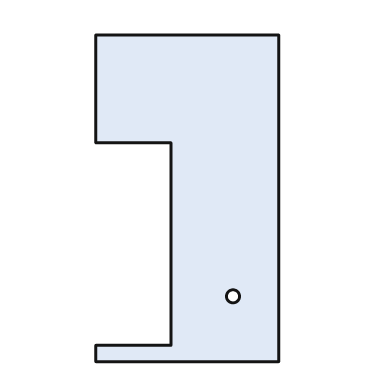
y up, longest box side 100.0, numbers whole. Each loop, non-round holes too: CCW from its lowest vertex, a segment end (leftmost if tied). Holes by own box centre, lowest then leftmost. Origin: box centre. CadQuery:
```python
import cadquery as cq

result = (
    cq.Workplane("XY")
    .moveTo(-28.0, -50.0)
    .lineTo(28.0, -50.0)
    .lineTo(28.0, 50.0)
    .lineTo(-28.0, 50.0)
    .lineTo(-28.0, 17.0)
    .lineTo(-5.0, 17.0)
    .lineTo(-5.0, -45.0)
    .lineTo(-28.0, -45.0)
    .close()
    .moveTo(14.0, -30.0)
    .circle(2.0)
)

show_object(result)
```